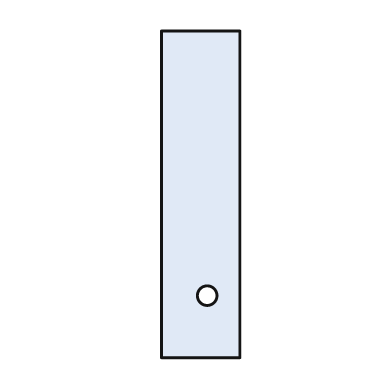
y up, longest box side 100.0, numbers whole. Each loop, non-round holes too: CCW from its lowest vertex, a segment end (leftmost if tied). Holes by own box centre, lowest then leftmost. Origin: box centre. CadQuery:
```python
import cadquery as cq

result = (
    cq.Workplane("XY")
    .moveTo(-12.0, -50.0)
    .lineTo(12.0, -50.0)
    .lineTo(12.0, 50.0)
    .lineTo(-12.0, 50.0)
    .close()
    .moveTo(2.0, -31.0)
    .circle(3.0)
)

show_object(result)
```